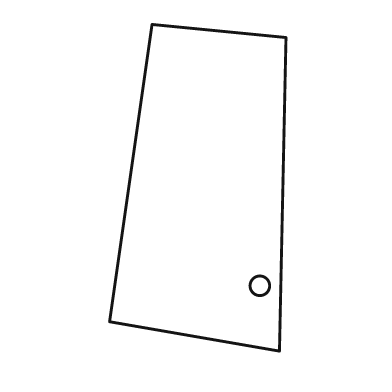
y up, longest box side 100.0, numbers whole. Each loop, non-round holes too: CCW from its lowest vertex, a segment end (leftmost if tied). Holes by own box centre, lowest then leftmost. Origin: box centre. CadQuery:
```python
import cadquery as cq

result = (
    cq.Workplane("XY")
    .moveTo(25.0, -50.0)
    .lineTo(27.0, 46.0)
    .lineTo(-14.0, 50.0)
    .lineTo(-27.0, -41.0)
    .close()
    .moveTo(19.0, -30.0)
    .circle(3.0)
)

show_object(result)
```